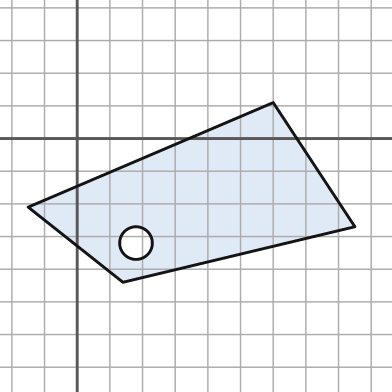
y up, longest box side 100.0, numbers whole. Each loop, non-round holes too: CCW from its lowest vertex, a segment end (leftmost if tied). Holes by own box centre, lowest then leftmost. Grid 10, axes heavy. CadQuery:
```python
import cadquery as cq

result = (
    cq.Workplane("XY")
    .moveTo(14.0, -44.0)
    .lineTo(85.0, -27.0)
    .lineTo(60.0, 11.0)
    .lineTo(-15.0, -21.0)
    .close()
    .moveTo(18.0, -32.0)
    .circle(5.0)
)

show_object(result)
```